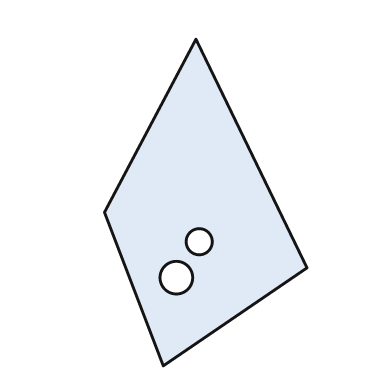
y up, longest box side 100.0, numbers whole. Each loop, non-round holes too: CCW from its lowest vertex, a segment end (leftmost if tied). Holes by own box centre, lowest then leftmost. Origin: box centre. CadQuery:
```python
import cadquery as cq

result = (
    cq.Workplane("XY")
    .moveTo(-13.0, -50.0)
    .lineTo(31.0, -20.0)
    .lineTo(-3.0, 50.0)
    .lineTo(-31.0, -3.0)
    .close()
    .moveTo(-9.0, -23.0)
    .circle(5.0)
    .moveTo(-2.0, -12.0)
    .circle(4.0)
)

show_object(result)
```